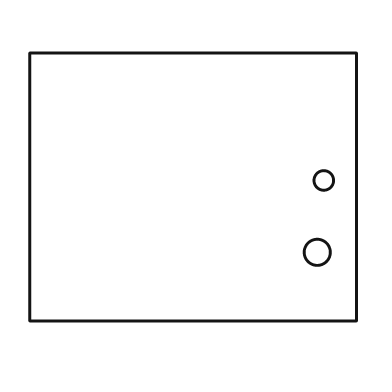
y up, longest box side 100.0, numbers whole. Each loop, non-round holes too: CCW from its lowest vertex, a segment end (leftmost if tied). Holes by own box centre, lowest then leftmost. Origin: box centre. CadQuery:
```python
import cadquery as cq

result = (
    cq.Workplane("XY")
    .moveTo(-50.0, -41.0)
    .lineTo(50.0, -41.0)
    .lineTo(50.0, 41.0)
    .lineTo(-50.0, 41.0)
    .close()
    .moveTo(38.0, -20.0)
    .circle(4.0)
    .moveTo(40.0, 2.0)
    .circle(3.0)
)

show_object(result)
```